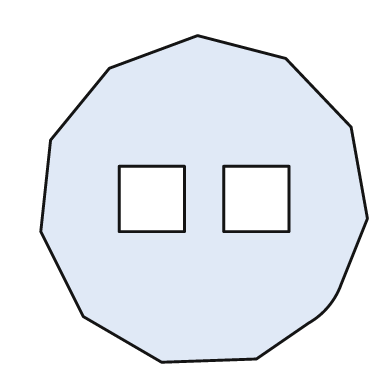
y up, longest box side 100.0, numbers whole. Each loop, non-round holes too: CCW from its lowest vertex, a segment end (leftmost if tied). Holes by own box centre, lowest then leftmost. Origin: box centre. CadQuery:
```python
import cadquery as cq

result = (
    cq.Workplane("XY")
    .moveTo(-13.0, -50.0)
    .lineTo(16.0, -49.0)
    .lineTo(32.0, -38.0)
    .threePointArc((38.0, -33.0), (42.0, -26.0))
    .lineTo(50.0, -6.0)
    .lineTo(45.0, 22.0)
    .lineTo(25.0, 43.0)
    .lineTo(-2.0, 50.0)
    .lineTo(-29.0, 40.0)
    .lineTo(-47.0, 18.0)
    .lineTo(-50.0, -10.0)
    .lineTo(-37.0, -36.0)
    .close()
    .moveTo(-26.0, -10.0)
    .lineTo(-6.0, -10.0)
    .lineTo(-6.0, 10.0)
    .lineTo(-26.0, 10.0)
    .close()
    .moveTo(6.0, -10.0)
    .lineTo(26.0, -10.0)
    .lineTo(26.0, 10.0)
    .lineTo(6.0, 10.0)
    .close()
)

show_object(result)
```